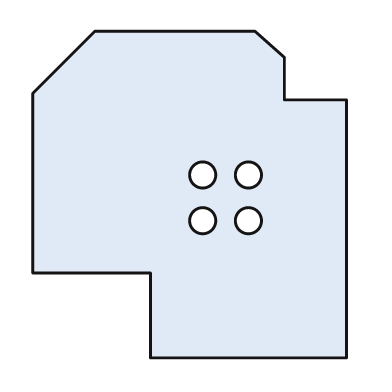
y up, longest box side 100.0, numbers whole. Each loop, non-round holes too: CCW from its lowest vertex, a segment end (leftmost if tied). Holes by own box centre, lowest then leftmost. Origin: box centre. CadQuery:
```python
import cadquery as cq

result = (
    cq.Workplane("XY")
    .moveTo(-12.0, -50.0)
    .lineTo(48.0, -50.0)
    .lineTo(48.0, 29.0)
    .lineTo(29.0, 29.0)
    .lineTo(29.0, 42.0)
    .lineTo(20.0, 50.0)
    .lineTo(-29.0, 50.0)
    .lineTo(-48.0, 31.0)
    .lineTo(-48.0, -24.0)
    .lineTo(-12.0, -24.0)
    .close()
    .moveTo(4.0, -8.0)
    .circle(4.0)
    .moveTo(18.0, -8.0)
    .circle(4.0)
    .moveTo(4.0, 6.0)
    .circle(4.0)
    .moveTo(18.0, 6.0)
    .circle(4.0)
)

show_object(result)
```